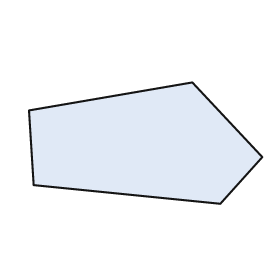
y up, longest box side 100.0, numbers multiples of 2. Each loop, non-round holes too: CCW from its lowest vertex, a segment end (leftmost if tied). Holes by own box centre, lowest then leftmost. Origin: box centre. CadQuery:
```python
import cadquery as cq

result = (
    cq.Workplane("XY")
    .moveTo(32.0, -26.0)
    .lineTo(50.0, -6.0)
    .lineTo(20.0, 26.0)
    .lineTo(-50.0, 14.0)
    .lineTo(-48.0, -18.0)
    .close()
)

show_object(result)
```